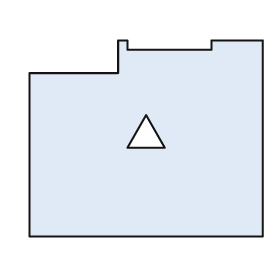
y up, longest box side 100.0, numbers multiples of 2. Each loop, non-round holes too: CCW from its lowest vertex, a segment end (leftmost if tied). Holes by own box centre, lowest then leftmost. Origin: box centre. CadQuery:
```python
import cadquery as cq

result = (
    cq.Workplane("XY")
    .moveTo(-50.0, -42.0)
    .lineTo(50.0, -42.0)
    .lineTo(50.0, 42.0)
    .lineTo(28.0, 42.0)
    .lineTo(28.0, 38.0)
    .lineTo(-8.0, 38.0)
    .lineTo(-8.0, 42.0)
    .lineTo(-12.0, 42.0)
    .lineTo(-12.0, 28.0)
    .lineTo(-50.0, 28.0)
    .close()
    .moveTo(-8.0, -4.0)
    .lineTo(8.0, -4.0)
    .lineTo(0.0, 10.0)
    .close()
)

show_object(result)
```